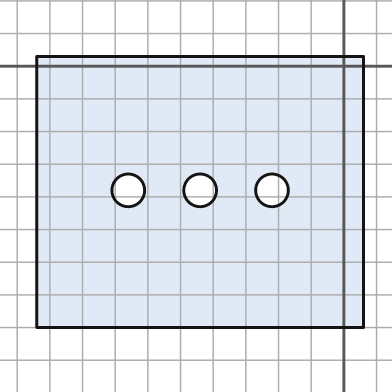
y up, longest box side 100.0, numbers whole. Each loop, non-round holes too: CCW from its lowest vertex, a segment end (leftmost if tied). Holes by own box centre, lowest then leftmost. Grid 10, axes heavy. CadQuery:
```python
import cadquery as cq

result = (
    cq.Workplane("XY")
    .moveTo(-94.0, -80.0)
    .lineTo(6.0, -80.0)
    .lineTo(6.0, 3.0)
    .lineTo(-94.0, 3.0)
    .close()
    .moveTo(-66.0, -38.0)
    .circle(5.0)
    .moveTo(-44.0, -38.0)
    .circle(5.0)
    .moveTo(-22.0, -38.0)
    .circle(5.0)
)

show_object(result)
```